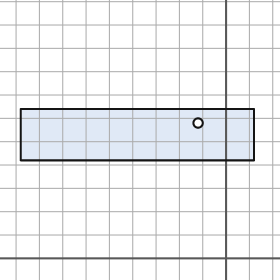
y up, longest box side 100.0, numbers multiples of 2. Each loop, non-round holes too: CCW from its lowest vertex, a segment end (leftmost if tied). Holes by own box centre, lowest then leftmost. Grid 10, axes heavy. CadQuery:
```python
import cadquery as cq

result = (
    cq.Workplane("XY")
    .moveTo(-88.0, 42.0)
    .lineTo(12.0, 42.0)
    .lineTo(12.0, 64.0)
    .lineTo(-88.0, 64.0)
    .close()
    .moveTo(-12.0, 58.0)
    .circle(2.0)
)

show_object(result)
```